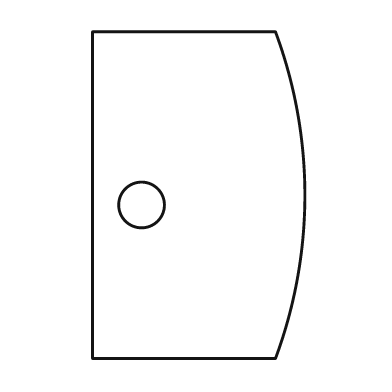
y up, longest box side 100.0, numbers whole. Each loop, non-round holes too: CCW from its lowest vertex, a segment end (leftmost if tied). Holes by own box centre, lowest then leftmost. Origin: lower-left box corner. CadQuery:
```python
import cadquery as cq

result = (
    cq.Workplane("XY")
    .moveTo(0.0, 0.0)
    .lineTo(56.0, 0.0)
    .threePointArc((65.0, 50.0), (56.0, 100.0))
    .lineTo(0.0, 100.0)
    .close()
    .moveTo(15.0, 47.0)
    .circle(7.0)
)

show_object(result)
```